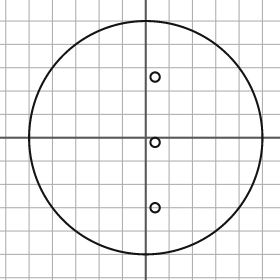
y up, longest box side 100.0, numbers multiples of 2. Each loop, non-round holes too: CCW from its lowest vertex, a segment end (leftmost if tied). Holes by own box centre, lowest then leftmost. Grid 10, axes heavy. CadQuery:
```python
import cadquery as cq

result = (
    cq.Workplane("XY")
    .moveTo(0.0, 0.0)
    .circle(50.0)
    .moveTo(4.0, -30.0)
    .circle(2.0)
    .moveTo(4.0, -2.0)
    .circle(2.0)
    .moveTo(4.0, 26.0)
    .circle(2.0)
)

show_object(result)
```